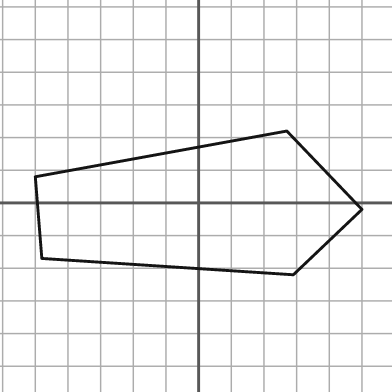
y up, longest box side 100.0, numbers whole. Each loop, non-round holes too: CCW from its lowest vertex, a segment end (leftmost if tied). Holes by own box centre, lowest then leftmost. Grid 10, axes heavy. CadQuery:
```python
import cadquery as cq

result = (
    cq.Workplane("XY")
    .moveTo(29.0, -22.0)
    .lineTo(50.0, -2.0)
    .lineTo(27.0, 22.0)
    .lineTo(-50.0, 8.0)
    .lineTo(-48.0, -17.0)
    .close()
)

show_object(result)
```